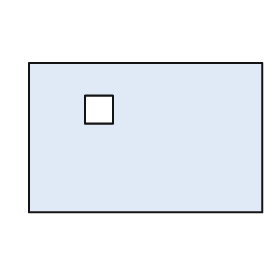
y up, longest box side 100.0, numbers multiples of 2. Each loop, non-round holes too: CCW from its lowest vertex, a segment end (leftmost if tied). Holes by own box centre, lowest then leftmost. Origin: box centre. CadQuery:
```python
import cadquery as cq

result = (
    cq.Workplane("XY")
    .moveTo(-50.0, -32.0)
    .lineTo(50.0, -32.0)
    .lineTo(50.0, 32.0)
    .lineTo(-50.0, 32.0)
    .close()
    .moveTo(-26.0, 6.0)
    .lineTo(-14.0, 6.0)
    .lineTo(-14.0, 18.0)
    .lineTo(-26.0, 18.0)
    .close()
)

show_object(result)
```